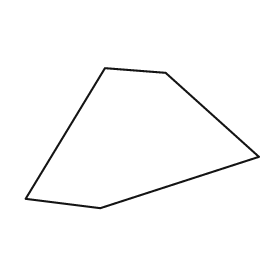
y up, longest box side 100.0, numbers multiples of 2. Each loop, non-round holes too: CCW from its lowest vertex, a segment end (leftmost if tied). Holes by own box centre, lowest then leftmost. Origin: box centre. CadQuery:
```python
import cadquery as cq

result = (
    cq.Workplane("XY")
    .moveTo(-18.0, -30.0)
    .lineTo(50.0, -8.0)
    .lineTo(10.0, 28.0)
    .lineTo(-16.0, 30.0)
    .lineTo(-50.0, -26.0)
    .close()
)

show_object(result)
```